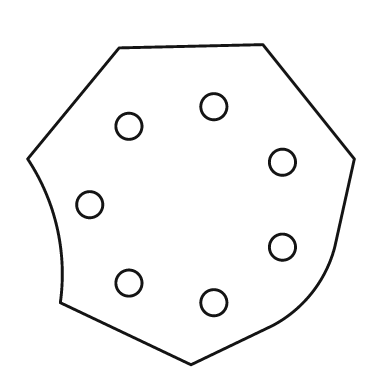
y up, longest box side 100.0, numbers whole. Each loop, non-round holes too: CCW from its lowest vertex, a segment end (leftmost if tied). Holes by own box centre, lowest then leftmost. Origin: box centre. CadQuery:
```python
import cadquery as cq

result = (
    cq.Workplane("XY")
    .moveTo(0.0, -49.0)
    .lineTo(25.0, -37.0)
    .threePointArc((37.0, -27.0), (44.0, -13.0))
    .lineTo(50.0, 14.0)
    .lineTo(22.0, 49.0)
    .lineTo(-22.0, 48.0)
    .lineTo(-50.0, 14.0)
    .threePointArc((-41.0, -7.0), (-40.0, -30.0))
    .close()
    .moveTo(7.0, -30.0)
    .circle(4.0)
    .moveTo(-19.0, -24.0)
    .circle(4.0)
    .moveTo(28.0, -13.0)
    .circle(4.0)
    .moveTo(-31.0, 0.0)
    .circle(4.0)
    .moveTo(28.0, 13.0)
    .circle(4.0)
    .moveTo(-19.0, 24.0)
    .circle(4.0)
    .moveTo(7.0, 30.0)
    .circle(4.0)
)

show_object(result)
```